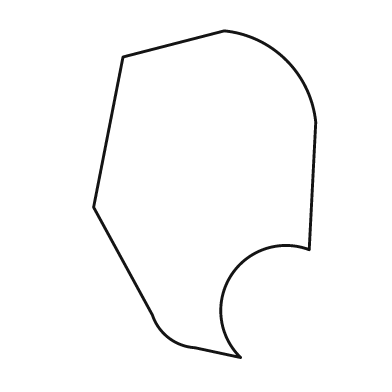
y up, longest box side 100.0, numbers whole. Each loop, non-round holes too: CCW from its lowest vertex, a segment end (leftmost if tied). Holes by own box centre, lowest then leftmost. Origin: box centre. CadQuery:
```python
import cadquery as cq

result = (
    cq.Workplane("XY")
    .moveTo(11.0, -50.0)
    .threePointArc((8.0, -25.0), (32.0, -17.0))
    .lineTo(34.0, 22.0)
    .threePointArc((25.0, 41.0), (6.0, 50.0))
    .lineTo(-25.0, 42.0)
    .lineTo(-34.0, -4.0)
    .lineTo(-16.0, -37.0)
    .threePointArc((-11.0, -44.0), (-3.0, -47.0))
    .close()
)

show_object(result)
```